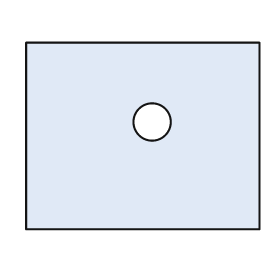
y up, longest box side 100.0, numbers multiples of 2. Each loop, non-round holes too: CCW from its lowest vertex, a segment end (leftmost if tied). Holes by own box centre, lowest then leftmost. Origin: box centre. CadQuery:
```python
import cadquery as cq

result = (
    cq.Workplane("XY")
    .moveTo(-50.0, -40.0)
    .lineTo(50.0, -40.0)
    .lineTo(50.0, 40.0)
    .lineTo(-50.0, 40.0)
    .close()
    .moveTo(4.0, 6.0)
    .circle(8.0)
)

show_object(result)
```